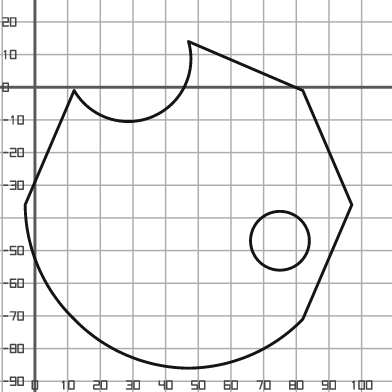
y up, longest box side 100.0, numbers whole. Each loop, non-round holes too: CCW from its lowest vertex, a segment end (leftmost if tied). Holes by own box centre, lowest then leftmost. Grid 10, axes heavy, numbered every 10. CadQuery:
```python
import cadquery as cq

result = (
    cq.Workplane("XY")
    .moveTo(47.0, -86.0)
    .threePointArc((66.0, -82.0), (82.0, -71.0))
    .lineTo(97.0, -36.0)
    .lineTo(82.0, -1.0)
    .lineTo(47.0, 14.0)
    .threePointArc((36.0, -9.0), (12.0, -1.0))
    .lineTo(-3.0, -36.0)
    .threePointArc((1.0, -55.0), (12.0, -71.0))
    .threePointArc((28.0, -82.0), (47.0, -86.0))
    .close()
    .moveTo(75.0, -47.0)
    .circle(9.0)
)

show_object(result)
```